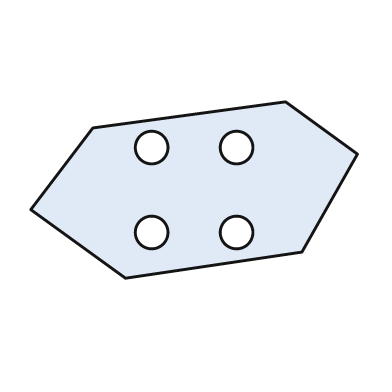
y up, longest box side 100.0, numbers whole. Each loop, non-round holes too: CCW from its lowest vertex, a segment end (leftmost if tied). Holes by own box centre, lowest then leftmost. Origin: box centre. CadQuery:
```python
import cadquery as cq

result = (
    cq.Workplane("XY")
    .moveTo(-21.0, -27.0)
    .lineTo(33.0, -19.0)
    .lineTo(50.0, 11.0)
    .lineTo(28.0, 27.0)
    .lineTo(-31.0, 19.0)
    .lineTo(-50.0, -6.0)
    .close()
    .moveTo(-13.0, -13.0)
    .circle(5.0)
    .moveTo(13.0, -13.0)
    .circle(5.0)
    .moveTo(-13.0, 13.0)
    .circle(5.0)
    .moveTo(13.0, 13.0)
    .circle(5.0)
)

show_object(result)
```